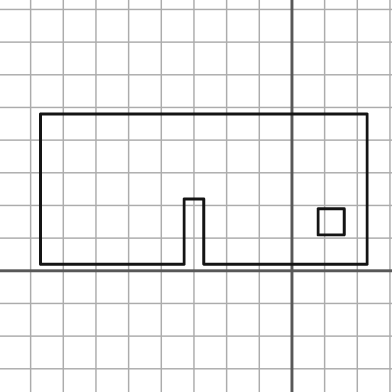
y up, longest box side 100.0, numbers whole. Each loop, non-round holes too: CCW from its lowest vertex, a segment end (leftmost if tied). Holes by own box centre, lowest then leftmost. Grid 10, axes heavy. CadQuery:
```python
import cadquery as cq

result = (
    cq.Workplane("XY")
    .moveTo(-77.0, 2.0)
    .lineTo(-33.0, 2.0)
    .lineTo(-33.0, 22.0)
    .lineTo(-27.0, 22.0)
    .lineTo(-27.0, 2.0)
    .lineTo(23.0, 2.0)
    .lineTo(23.0, 48.0)
    .lineTo(-77.0, 48.0)
    .close()
    .moveTo(8.0, 11.0)
    .lineTo(16.0, 11.0)
    .lineTo(16.0, 19.0)
    .lineTo(8.0, 19.0)
    .close()
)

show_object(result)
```